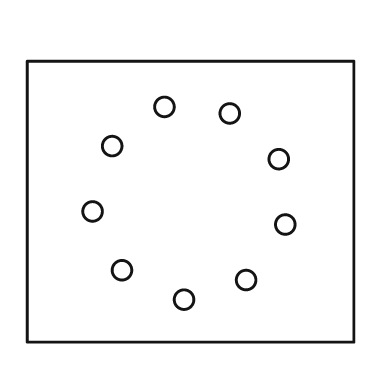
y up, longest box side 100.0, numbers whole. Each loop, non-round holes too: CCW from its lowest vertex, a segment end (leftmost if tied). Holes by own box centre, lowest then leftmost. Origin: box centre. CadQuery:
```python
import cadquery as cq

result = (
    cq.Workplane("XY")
    .moveTo(-50.0, -43.0)
    .lineTo(50.0, -43.0)
    .lineTo(50.0, 43.0)
    .lineTo(-50.0, 43.0)
    .close()
    .moveTo(-2.0, -30.0)
    .circle(3.0)
    .moveTo(17.0, -24.0)
    .circle(3.0)
    .moveTo(-21.0, -21.0)
    .circle(3.0)
    .moveTo(29.0, -7.0)
    .circle(3.0)
    .moveTo(-30.0, -3.0)
    .circle(3.0)
    .moveTo(27.0, 13.0)
    .circle(3.0)
    .moveTo(-24.0, 17.0)
    .circle(3.0)
    .moveTo(12.0, 27.0)
    .circle(3.0)
    .moveTo(-8.0, 29.0)
    .circle(3.0)
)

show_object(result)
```